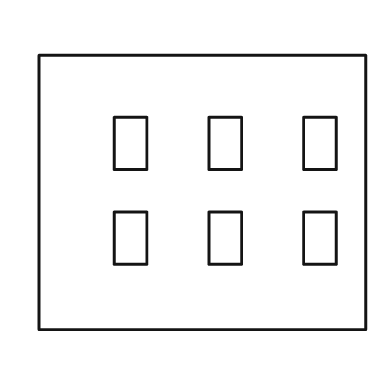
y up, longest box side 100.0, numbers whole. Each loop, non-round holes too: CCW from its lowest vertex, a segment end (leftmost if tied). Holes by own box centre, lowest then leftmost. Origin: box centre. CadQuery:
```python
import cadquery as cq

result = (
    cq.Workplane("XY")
    .moveTo(-50.0, -42.0)
    .lineTo(50.0, -42.0)
    .lineTo(50.0, 42.0)
    .lineTo(-50.0, 42.0)
    .close()
    .moveTo(-27.0, -22.0)
    .lineTo(-17.0, -22.0)
    .lineTo(-17.0, -6.0)
    .lineTo(-27.0, -6.0)
    .close()
    .moveTo(2.0, -22.0)
    .lineTo(12.0, -22.0)
    .lineTo(12.0, -6.0)
    .lineTo(2.0, -6.0)
    .close()
    .moveTo(31.0, -22.0)
    .lineTo(41.0, -22.0)
    .lineTo(41.0, -6.0)
    .lineTo(31.0, -6.0)
    .close()
    .moveTo(-27.0, 7.0)
    .lineTo(-17.0, 7.0)
    .lineTo(-17.0, 23.0)
    .lineTo(-27.0, 23.0)
    .close()
    .moveTo(2.0, 7.0)
    .lineTo(12.0, 7.0)
    .lineTo(12.0, 23.0)
    .lineTo(2.0, 23.0)
    .close()
    .moveTo(31.0, 7.0)
    .lineTo(41.0, 7.0)
    .lineTo(41.0, 23.0)
    .lineTo(31.0, 23.0)
    .close()
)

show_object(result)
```